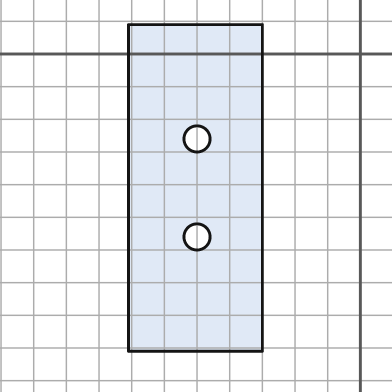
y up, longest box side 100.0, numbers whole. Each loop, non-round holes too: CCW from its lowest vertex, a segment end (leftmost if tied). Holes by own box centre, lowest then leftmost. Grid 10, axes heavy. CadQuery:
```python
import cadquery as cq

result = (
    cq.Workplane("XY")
    .moveTo(-71.0, -91.0)
    .lineTo(-30.0, -91.0)
    .lineTo(-30.0, 9.0)
    .lineTo(-71.0, 9.0)
    .close()
    .moveTo(-50.0, -56.0)
    .circle(4.0)
    .moveTo(-50.0, -26.0)
    .circle(4.0)
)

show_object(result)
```